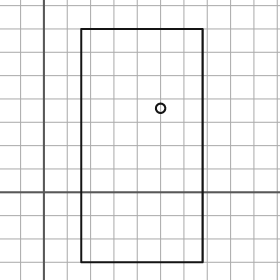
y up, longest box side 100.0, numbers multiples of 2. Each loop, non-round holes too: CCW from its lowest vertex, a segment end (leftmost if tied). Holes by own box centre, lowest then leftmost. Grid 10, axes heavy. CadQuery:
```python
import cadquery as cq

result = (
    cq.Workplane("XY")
    .moveTo(16.0, -30.0)
    .lineTo(68.0, -30.0)
    .lineTo(68.0, 70.0)
    .lineTo(16.0, 70.0)
    .close()
    .moveTo(50.0, 36.0)
    .circle(2.0)
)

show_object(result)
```